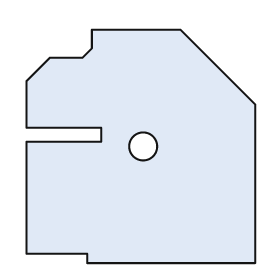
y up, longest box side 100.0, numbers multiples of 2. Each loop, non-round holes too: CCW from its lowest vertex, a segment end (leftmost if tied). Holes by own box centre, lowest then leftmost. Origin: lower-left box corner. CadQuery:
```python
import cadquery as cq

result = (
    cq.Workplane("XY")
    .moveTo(26.0, 0.0)
    .lineTo(98.0, 0.0)
    .lineTo(98.0, 68.0)
    .lineTo(66.0, 100.0)
    .lineTo(28.0, 100.0)
    .lineTo(28.0, 92.0)
    .lineTo(24.0, 88.0)
    .lineTo(10.0, 88.0)
    .lineTo(0.0, 78.0)
    .lineTo(0.0, 58.0)
    .lineTo(32.0, 58.0)
    .lineTo(32.0, 52.0)
    .lineTo(0.0, 52.0)
    .lineTo(0.0, 4.0)
    .lineTo(26.0, 4.0)
    .close()
    .moveTo(50.0, 50.0)
    .circle(6.0)
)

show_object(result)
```